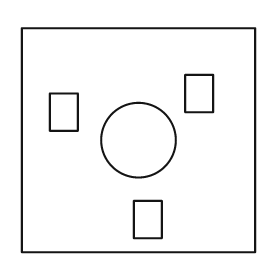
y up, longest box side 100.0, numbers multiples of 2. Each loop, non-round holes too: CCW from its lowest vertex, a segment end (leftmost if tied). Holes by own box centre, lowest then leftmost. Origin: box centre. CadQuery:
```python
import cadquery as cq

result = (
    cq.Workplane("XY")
    .moveTo(-50.0, -48.0)
    .lineTo(50.0, -48.0)
    .lineTo(50.0, 48.0)
    .lineTo(-50.0, 48.0)
    .close()
    .moveTo(-2.0, -42.0)
    .lineTo(10.0, -42.0)
    .lineTo(10.0, -26.0)
    .lineTo(-2.0, -26.0)
    .close()
    .moveTo(0.0, 0.0)
    .circle(16.0)
    .moveTo(-38.0, 4.0)
    .lineTo(-26.0, 4.0)
    .lineTo(-26.0, 20.0)
    .lineTo(-38.0, 20.0)
    .close()
    .moveTo(20.0, 12.0)
    .lineTo(32.0, 12.0)
    .lineTo(32.0, 28.0)
    .lineTo(20.0, 28.0)
    .close()
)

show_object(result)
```